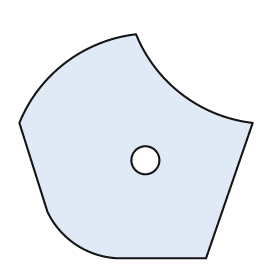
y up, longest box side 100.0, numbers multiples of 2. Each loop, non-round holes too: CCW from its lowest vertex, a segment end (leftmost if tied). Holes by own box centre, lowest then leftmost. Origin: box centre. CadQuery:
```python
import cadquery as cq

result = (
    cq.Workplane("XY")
    .moveTo(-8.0, -48.0)
    .lineTo(30.0, -48.0)
    .lineTo(50.0, 10.0)
    .threePointArc((20.0, 22.0), (0.0, 48.0))
    .threePointArc((-30.0, 36.0), (-50.0, 10.0))
    .lineTo(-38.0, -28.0)
    .threePointArc((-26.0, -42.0), (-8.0, -48.0))
    .close()
    .moveTo(4.0, -6.0)
    .circle(6.0)
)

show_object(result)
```